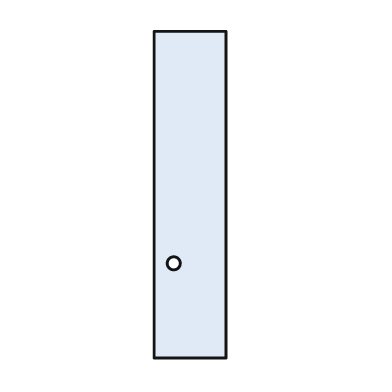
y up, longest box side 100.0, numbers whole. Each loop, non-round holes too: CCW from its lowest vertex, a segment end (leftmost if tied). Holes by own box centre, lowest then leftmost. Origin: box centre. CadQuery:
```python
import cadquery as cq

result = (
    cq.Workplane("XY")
    .moveTo(-11.0, -50.0)
    .lineTo(11.0, -50.0)
    .lineTo(11.0, 50.0)
    .lineTo(-11.0, 50.0)
    .close()
    .moveTo(-5.0, -21.0)
    .circle(2.0)
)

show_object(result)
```